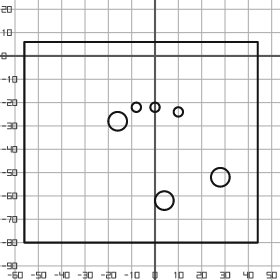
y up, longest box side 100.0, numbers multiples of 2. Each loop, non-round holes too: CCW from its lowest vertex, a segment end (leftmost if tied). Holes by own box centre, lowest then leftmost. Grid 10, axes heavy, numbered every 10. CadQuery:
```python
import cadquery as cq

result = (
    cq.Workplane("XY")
    .moveTo(-56.0, -80.0)
    .lineTo(44.0, -80.0)
    .lineTo(44.0, 6.0)
    .lineTo(-56.0, 6.0)
    .close()
    .moveTo(4.0, -62.0)
    .circle(4.0)
    .moveTo(28.0, -52.0)
    .circle(4.0)
    .moveTo(-16.0, -28.0)
    .circle(4.0)
    .moveTo(10.0, -24.0)
    .circle(2.0)
    .moveTo(-8.0, -22.0)
    .circle(2.0)
    .moveTo(0.0, -22.0)
    .circle(2.0)
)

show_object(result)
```